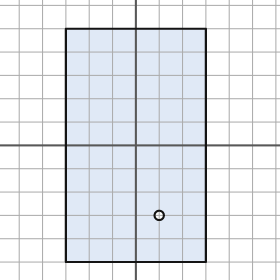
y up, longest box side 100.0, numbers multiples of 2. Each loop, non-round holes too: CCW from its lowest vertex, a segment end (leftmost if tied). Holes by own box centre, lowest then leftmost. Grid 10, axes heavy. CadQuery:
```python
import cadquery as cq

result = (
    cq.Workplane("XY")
    .moveTo(-30.0, -50.0)
    .lineTo(30.0, -50.0)
    .lineTo(30.0, 50.0)
    .lineTo(-30.0, 50.0)
    .close()
    .moveTo(10.0, -30.0)
    .circle(2.0)
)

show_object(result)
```